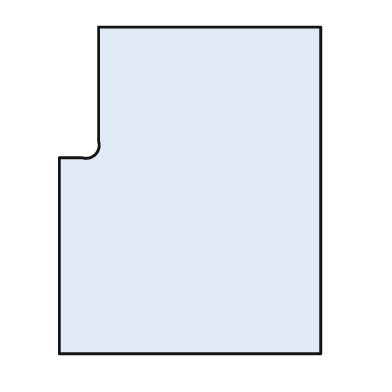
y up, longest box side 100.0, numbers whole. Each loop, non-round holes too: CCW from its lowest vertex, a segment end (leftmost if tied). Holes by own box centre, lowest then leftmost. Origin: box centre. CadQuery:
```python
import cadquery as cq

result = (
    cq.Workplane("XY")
    .moveTo(-40.0, -50.0)
    .lineTo(40.0, -50.0)
    .lineTo(40.0, 50.0)
    .lineTo(-28.0, 50.0)
    .lineTo(-28.0, 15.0)
    .threePointArc((-29.0, 11.0), (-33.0, 10.0))
    .lineTo(-40.0, 10.0)
    .close()
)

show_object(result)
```